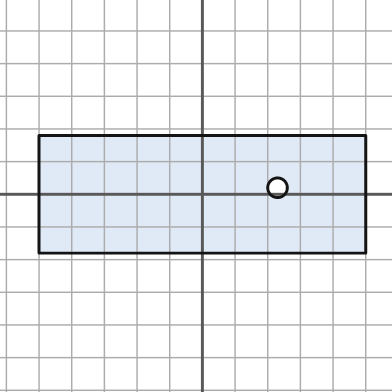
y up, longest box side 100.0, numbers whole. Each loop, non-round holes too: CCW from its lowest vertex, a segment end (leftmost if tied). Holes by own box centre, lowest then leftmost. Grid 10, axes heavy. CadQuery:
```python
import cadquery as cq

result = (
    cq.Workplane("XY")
    .moveTo(-50.0, -18.0)
    .lineTo(50.0, -18.0)
    .lineTo(50.0, 18.0)
    .lineTo(-50.0, 18.0)
    .close()
    .moveTo(23.0, 2.0)
    .circle(3.0)
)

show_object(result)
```